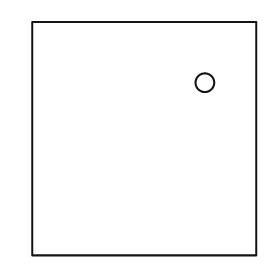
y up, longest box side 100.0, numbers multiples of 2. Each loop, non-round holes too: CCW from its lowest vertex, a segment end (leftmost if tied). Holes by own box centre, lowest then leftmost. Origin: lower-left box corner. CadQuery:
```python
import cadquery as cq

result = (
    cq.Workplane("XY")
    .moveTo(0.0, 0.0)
    .lineTo(96.0, 0.0)
    .lineTo(96.0, 100.0)
    .lineTo(0.0, 100.0)
    .close()
    .moveTo(74.0, 74.0)
    .circle(4.0)
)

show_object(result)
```